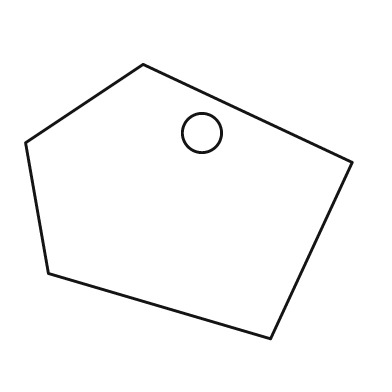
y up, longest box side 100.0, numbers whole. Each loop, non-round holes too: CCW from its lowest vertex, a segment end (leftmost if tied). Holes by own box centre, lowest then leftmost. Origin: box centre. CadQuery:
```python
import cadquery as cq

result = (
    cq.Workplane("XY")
    .moveTo(25.0, -42.0)
    .lineTo(50.0, 12.0)
    .lineTo(-14.0, 42.0)
    .lineTo(-50.0, 18.0)
    .lineTo(-43.0, -22.0)
    .close()
    .moveTo(4.0, 21.0)
    .circle(6.0)
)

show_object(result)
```